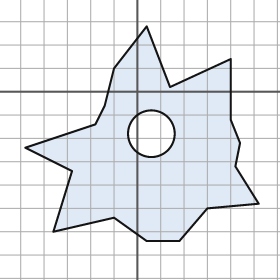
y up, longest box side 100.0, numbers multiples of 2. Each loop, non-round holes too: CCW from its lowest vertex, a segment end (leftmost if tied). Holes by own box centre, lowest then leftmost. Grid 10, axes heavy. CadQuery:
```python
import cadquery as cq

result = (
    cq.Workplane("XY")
    .moveTo(4.0, -64.0)
    .lineTo(18.0, -64.0)
    .lineTo(30.0, -50.0)
    .lineTo(52.0, -48.0)
    .lineTo(42.0, -32.0)
    .lineTo(44.0, -22.0)
    .lineTo(40.0, -12.0)
    .lineTo(40.0, 14.0)
    .lineTo(14.0, 2.0)
    .lineTo(4.0, 28.0)
    .lineTo(-10.0, 10.0)
    .lineTo(-14.0, -6.0)
    .lineTo(-18.0, -14.0)
    .lineTo(-48.0, -24.0)
    .lineTo(-28.0, -34.0)
    .lineTo(-36.0, -60.0)
    .lineTo(-10.0, -54.0)
    .close()
    .moveTo(6.0, -18.0)
    .circle(10.0)
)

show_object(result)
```